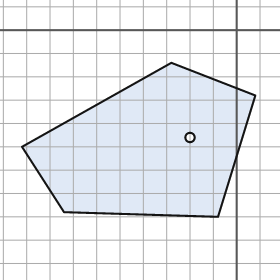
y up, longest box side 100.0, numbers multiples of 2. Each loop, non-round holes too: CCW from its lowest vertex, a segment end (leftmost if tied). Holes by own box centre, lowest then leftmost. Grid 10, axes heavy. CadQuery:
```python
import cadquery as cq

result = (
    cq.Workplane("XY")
    .moveTo(-8.0, -80.0)
    .lineTo(8.0, -28.0)
    .lineTo(-28.0, -14.0)
    .lineTo(-92.0, -50.0)
    .lineTo(-74.0, -78.0)
    .close()
    .moveTo(-20.0, -46.0)
    .circle(2.0)
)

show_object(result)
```